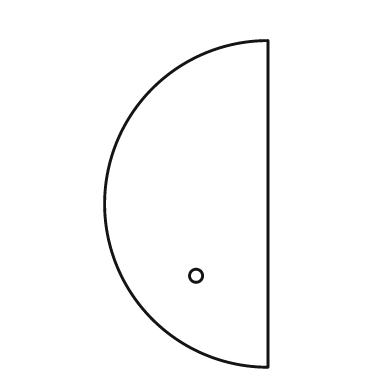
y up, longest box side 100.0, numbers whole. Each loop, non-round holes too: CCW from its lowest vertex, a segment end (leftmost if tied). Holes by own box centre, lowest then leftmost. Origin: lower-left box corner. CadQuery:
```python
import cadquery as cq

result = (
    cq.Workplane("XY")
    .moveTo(50.0, 0.0)
    .lineTo(50.0, 100.0)
    .threePointArc((0.0, 50.0), (50.0, 0.0))
    .close()
    .moveTo(28.0, 28.0)
    .circle(2.0)
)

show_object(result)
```